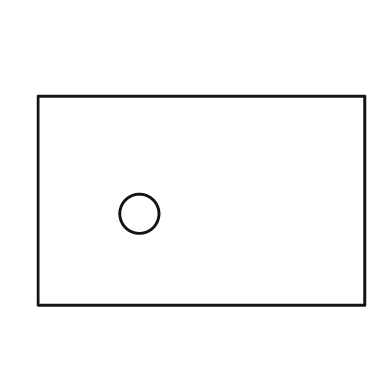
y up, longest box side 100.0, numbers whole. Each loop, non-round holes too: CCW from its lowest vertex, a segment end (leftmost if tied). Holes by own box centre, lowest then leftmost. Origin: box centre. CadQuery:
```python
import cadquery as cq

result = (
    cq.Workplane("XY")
    .moveTo(-50.0, -32.0)
    .lineTo(50.0, -32.0)
    .lineTo(50.0, 32.0)
    .lineTo(-50.0, 32.0)
    .close()
    .moveTo(-19.0, -4.0)
    .circle(6.0)
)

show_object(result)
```